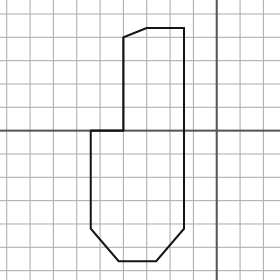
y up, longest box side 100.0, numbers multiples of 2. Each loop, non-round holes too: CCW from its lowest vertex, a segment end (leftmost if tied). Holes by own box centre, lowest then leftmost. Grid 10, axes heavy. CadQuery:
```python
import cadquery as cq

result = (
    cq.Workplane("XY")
    .moveTo(-42.0, -56.0)
    .lineTo(-26.0, -56.0)
    .lineTo(-14.0, -42.0)
    .lineTo(-14.0, 44.0)
    .lineTo(-30.0, 44.0)
    .lineTo(-40.0, 40.0)
    .lineTo(-40.0, 0.0)
    .lineTo(-54.0, 0.0)
    .lineTo(-54.0, -42.0)
    .close()
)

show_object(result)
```